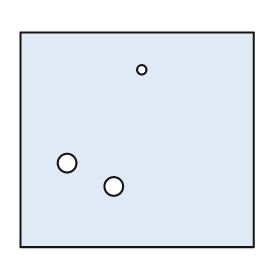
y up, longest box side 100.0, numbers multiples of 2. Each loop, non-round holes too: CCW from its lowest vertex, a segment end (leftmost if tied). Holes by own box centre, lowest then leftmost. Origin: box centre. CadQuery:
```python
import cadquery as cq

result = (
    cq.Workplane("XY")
    .moveTo(-50.0, -46.0)
    .lineTo(50.0, -46.0)
    .lineTo(50.0, 46.0)
    .lineTo(-50.0, 46.0)
    .close()
    .moveTo(-10.0, -20.0)
    .circle(4.0)
    .moveTo(-30.0, -10.0)
    .circle(4.0)
    .moveTo(2.0, 30.0)
    .circle(2.0)
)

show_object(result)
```